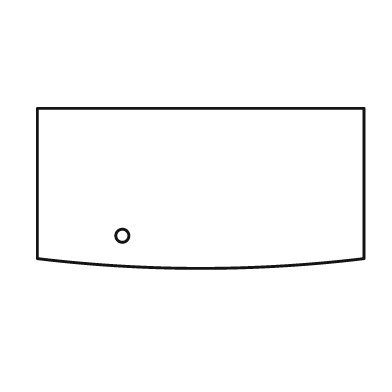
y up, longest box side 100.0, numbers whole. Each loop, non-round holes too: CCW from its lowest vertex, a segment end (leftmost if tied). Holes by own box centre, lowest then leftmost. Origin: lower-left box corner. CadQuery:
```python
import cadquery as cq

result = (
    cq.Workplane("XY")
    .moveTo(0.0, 3.0)
    .threePointArc((50.0, 0.0), (100.0, 3.0))
    .lineTo(100.0, 49.0)
    .lineTo(0.0, 49.0)
    .close()
    .moveTo(26.0, 10.0)
    .circle(2.0)
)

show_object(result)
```